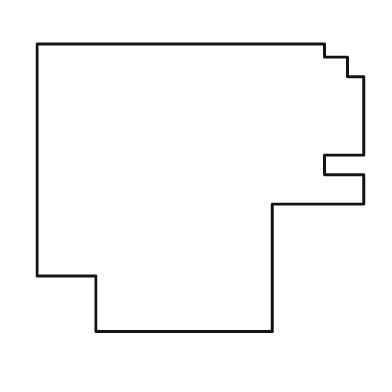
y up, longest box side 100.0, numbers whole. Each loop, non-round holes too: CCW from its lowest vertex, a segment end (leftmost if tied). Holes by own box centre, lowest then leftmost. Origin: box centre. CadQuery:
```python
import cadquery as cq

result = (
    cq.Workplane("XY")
    .moveTo(-32.0, -44.0)
    .lineTo(22.0, -44.0)
    .lineTo(22.0, -5.0)
    .lineTo(50.0, -5.0)
    .lineTo(50.0, 4.0)
    .lineTo(38.0, 4.0)
    .lineTo(38.0, 10.0)
    .lineTo(50.0, 10.0)
    .lineTo(50.0, 34.0)
    .lineTo(45.0, 34.0)
    .lineTo(45.0, 40.0)
    .lineTo(38.0, 40.0)
    .lineTo(38.0, 44.0)
    .lineTo(-50.0, 44.0)
    .lineTo(-50.0, -27.0)
    .lineTo(-32.0, -27.0)
    .close()
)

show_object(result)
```